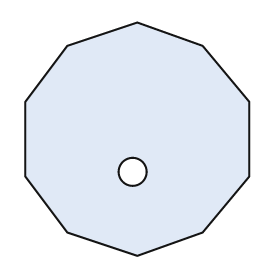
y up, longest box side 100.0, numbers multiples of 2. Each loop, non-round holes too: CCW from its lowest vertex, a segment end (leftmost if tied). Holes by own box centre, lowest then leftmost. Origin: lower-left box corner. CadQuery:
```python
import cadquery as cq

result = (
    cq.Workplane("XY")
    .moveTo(48.0, 0.0)
    .lineTo(76.0, 10.0)
    .lineTo(96.0, 34.0)
    .lineTo(96.0, 66.0)
    .lineTo(76.0, 90.0)
    .lineTo(48.0, 100.0)
    .lineTo(18.0, 90.0)
    .lineTo(0.0, 66.0)
    .lineTo(0.0, 34.0)
    .lineTo(18.0, 10.0)
    .close()
    .moveTo(46.0, 36.0)
    .circle(6.0)
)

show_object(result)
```